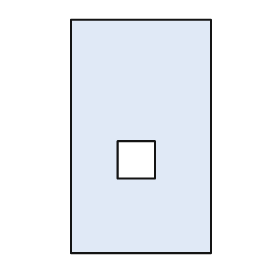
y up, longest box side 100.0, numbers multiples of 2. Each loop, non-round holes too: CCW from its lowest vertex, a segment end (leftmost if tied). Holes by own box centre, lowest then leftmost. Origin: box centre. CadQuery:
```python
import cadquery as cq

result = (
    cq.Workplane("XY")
    .moveTo(-30.0, -50.0)
    .lineTo(30.0, -50.0)
    .lineTo(30.0, 50.0)
    .lineTo(-30.0, 50.0)
    .close()
    .moveTo(-10.0, -18.0)
    .lineTo(6.0, -18.0)
    .lineTo(6.0, -2.0)
    .lineTo(-10.0, -2.0)
    .close()
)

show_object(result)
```